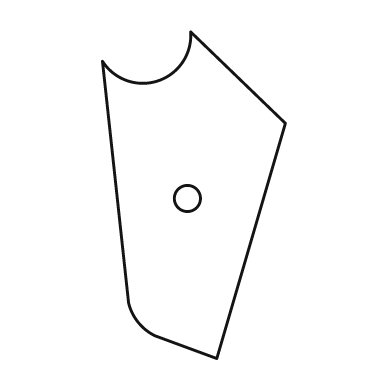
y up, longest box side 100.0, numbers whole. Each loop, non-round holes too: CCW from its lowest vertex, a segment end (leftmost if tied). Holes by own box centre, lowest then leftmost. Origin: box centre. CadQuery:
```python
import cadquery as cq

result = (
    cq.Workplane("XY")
    .moveTo(7.0, -50.0)
    .lineTo(28.0, 22.0)
    .lineTo(-1.0, 50.0)
    .threePointArc((-11.0, 35.0), (-28.0, 41.0))
    .lineTo(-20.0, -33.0)
    .threePointArc((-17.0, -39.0), (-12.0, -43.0))
    .close()
    .moveTo(-2.0, -1.0)
    .circle(4.0)
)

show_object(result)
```